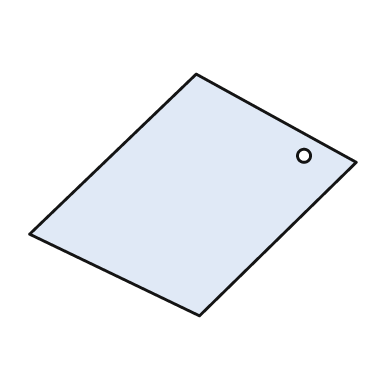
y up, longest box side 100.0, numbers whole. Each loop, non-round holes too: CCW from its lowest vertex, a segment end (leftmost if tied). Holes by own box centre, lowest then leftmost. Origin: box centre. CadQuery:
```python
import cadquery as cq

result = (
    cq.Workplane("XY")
    .moveTo(2.0, -37.0)
    .lineTo(50.0, 10.0)
    .lineTo(1.0, 37.0)
    .lineTo(-50.0, -12.0)
    .close()
    .moveTo(34.0, 12.0)
    .circle(2.0)
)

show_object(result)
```